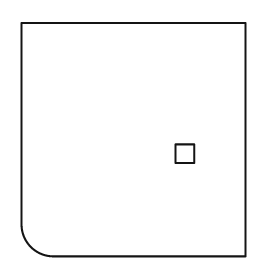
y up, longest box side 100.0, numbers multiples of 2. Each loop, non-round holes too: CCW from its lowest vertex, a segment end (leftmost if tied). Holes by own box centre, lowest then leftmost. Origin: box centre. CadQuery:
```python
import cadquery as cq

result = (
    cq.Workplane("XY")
    .moveTo(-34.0, -50.0)
    .lineTo(48.0, -50.0)
    .lineTo(48.0, 50.0)
    .lineTo(-48.0, 50.0)
    .lineTo(-48.0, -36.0)
    .threePointArc((-44.0, -46.0), (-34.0, -50.0))
    .close()
    .moveTo(18.0, -10.0)
    .lineTo(26.0, -10.0)
    .lineTo(26.0, -2.0)
    .lineTo(18.0, -2.0)
    .close()
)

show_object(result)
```